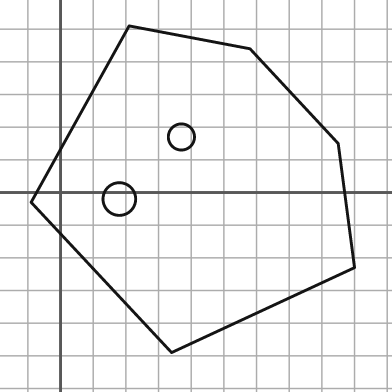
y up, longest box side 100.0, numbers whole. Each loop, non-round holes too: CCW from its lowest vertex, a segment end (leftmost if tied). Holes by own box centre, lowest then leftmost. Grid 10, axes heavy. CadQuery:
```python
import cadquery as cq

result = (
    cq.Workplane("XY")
    .moveTo(34.0, -49.0)
    .lineTo(90.0, -23.0)
    .lineTo(85.0, 15.0)
    .lineTo(58.0, 44.0)
    .lineTo(21.0, 51.0)
    .lineTo(-9.0, -3.0)
    .close()
    .moveTo(18.0, -2.0)
    .circle(5.0)
    .moveTo(37.0, 17.0)
    .circle(4.0)
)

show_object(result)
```